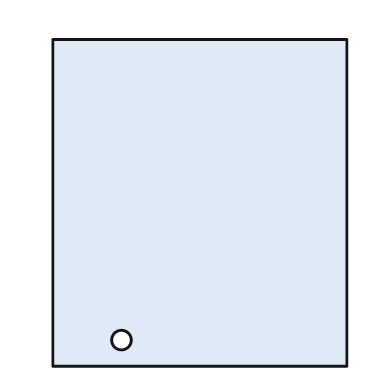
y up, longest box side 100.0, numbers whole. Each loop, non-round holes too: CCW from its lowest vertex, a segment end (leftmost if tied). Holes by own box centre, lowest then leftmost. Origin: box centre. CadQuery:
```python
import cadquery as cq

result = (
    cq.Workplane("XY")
    .moveTo(-45.0, -50.0)
    .lineTo(45.0, -50.0)
    .lineTo(45.0, 50.0)
    .lineTo(-45.0, 50.0)
    .close()
    .moveTo(-24.0, -42.0)
    .circle(3.0)
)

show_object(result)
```